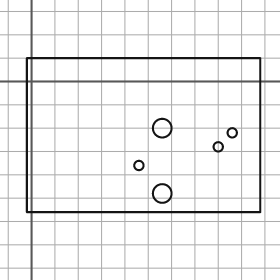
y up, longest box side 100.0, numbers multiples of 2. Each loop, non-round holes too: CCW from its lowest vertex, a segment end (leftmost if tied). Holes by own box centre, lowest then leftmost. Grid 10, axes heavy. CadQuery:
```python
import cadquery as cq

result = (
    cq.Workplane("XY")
    .moveTo(-2.0, -56.0)
    .lineTo(98.0, -56.0)
    .lineTo(98.0, 10.0)
    .lineTo(-2.0, 10.0)
    .close()
    .moveTo(56.0, -48.0)
    .circle(4.0)
    .moveTo(46.0, -36.0)
    .circle(2.0)
    .moveTo(80.0, -28.0)
    .circle(2.0)
    .moveTo(86.0, -22.0)
    .circle(2.0)
    .moveTo(56.0, -20.0)
    .circle(4.0)
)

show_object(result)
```